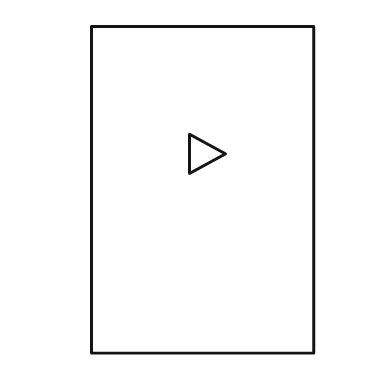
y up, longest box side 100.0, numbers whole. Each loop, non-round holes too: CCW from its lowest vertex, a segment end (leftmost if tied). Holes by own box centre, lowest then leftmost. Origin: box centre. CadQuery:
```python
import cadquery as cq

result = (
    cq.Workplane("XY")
    .moveTo(-34.0, -50.0)
    .lineTo(34.0, -50.0)
    .lineTo(34.0, 50.0)
    .lineTo(-34.0, 50.0)
    .close()
    .moveTo(-4.0, 5.0)
    .lineTo(7.0, 11.0)
    .lineTo(-4.0, 17.0)
    .close()
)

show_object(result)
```